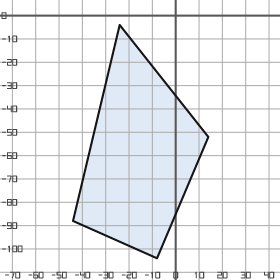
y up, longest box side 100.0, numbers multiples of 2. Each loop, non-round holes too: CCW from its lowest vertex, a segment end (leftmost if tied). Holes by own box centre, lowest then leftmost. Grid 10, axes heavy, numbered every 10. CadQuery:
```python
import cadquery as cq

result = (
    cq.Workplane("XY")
    .moveTo(-8.0, -104.0)
    .lineTo(14.0, -52.0)
    .lineTo(-24.0, -4.0)
    .lineTo(-44.0, -88.0)
    .close()
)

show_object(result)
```